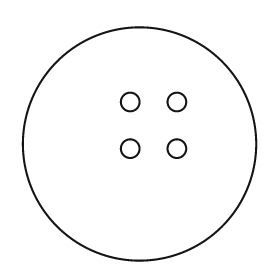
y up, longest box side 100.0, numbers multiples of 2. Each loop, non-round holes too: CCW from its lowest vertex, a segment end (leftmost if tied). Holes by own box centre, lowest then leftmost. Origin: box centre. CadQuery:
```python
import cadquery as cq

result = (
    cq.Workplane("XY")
    .moveTo(0.0, 0.0)
    .circle(50.0)
    .moveTo(-4.0, -2.0)
    .circle(4.0)
    .moveTo(16.0, -2.0)
    .circle(4.0)
    .moveTo(-4.0, 18.0)
    .circle(4.0)
    .moveTo(16.0, 18.0)
    .circle(4.0)
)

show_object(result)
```